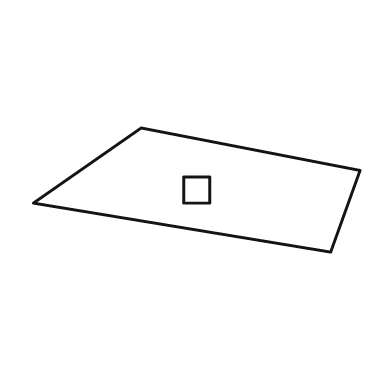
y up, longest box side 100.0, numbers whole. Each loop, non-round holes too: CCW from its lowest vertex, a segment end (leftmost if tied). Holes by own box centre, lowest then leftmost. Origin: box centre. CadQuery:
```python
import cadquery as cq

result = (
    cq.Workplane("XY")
    .moveTo(41.0, -19.0)
    .lineTo(50.0, 6.0)
    .lineTo(-17.0, 19.0)
    .lineTo(-50.0, -4.0)
    .close()
    .moveTo(-4.0, -4.0)
    .lineTo(4.0, -4.0)
    .lineTo(4.0, 4.0)
    .lineTo(-4.0, 4.0)
    .close()
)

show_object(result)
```